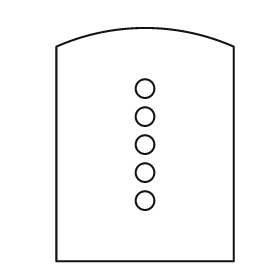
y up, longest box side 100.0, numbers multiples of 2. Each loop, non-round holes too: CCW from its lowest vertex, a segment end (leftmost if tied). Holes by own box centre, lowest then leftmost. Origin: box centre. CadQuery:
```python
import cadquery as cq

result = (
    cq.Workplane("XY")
    .moveTo(-38.0, -50.0)
    .lineTo(38.0, -50.0)
    .lineTo(38.0, 42.0)
    .threePointArc((0.0, 50.0), (-38.0, 42.0))
    .close()
    .moveTo(0.0, -24.0)
    .circle(4.0)
    .moveTo(0.0, -12.0)
    .circle(4.0)
    .moveTo(0.0, 0.0)
    .circle(4.0)
    .moveTo(0.0, 12.0)
    .circle(4.0)
    .moveTo(0.0, 24.0)
    .circle(4.0)
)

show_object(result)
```